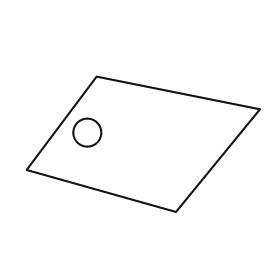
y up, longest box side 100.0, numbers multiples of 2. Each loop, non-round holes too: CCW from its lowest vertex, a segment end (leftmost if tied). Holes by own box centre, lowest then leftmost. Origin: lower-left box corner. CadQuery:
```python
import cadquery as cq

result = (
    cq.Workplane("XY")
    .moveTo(64.0, 0.0)
    .lineTo(100.0, 44.0)
    .lineTo(30.0, 58.0)
    .lineTo(0.0, 18.0)
    .close()
    .moveTo(26.0, 34.0)
    .circle(6.0)
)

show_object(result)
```